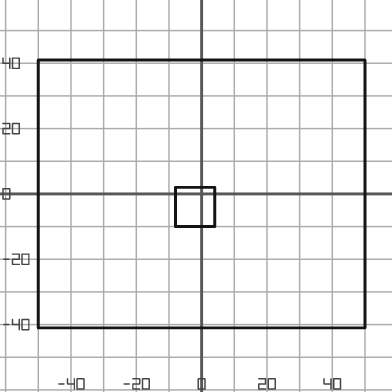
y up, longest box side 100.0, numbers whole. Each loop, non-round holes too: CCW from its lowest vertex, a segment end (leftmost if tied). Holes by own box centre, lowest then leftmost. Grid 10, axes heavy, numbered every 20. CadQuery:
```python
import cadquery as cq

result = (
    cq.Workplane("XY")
    .moveTo(-50.0, -41.0)
    .lineTo(50.0, -41.0)
    .lineTo(50.0, 41.0)
    .lineTo(-50.0, 41.0)
    .close()
    .moveTo(-8.0, -10.0)
    .lineTo(4.0, -10.0)
    .lineTo(4.0, 2.0)
    .lineTo(-8.0, 2.0)
    .close()
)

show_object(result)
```